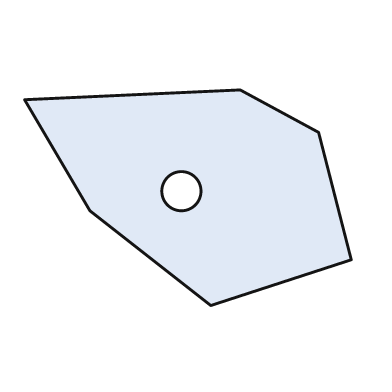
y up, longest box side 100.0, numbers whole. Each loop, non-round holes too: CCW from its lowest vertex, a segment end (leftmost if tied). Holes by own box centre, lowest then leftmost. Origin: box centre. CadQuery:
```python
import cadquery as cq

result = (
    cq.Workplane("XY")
    .moveTo(7.0, -33.0)
    .lineTo(50.0, -19.0)
    .lineTo(40.0, 20.0)
    .lineTo(16.0, 33.0)
    .lineTo(-50.0, 30.0)
    .lineTo(-30.0, -4.0)
    .close()
    .moveTo(-2.0, 2.0)
    .circle(6.0)
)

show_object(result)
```